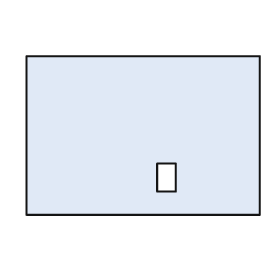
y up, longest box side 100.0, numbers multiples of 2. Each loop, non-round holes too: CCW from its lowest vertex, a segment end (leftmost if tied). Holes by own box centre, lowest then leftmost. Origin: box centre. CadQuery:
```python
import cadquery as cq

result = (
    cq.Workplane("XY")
    .moveTo(-50.0, -34.0)
    .lineTo(50.0, -34.0)
    .lineTo(50.0, 34.0)
    .lineTo(-50.0, 34.0)
    .close()
    .moveTo(6.0, -24.0)
    .lineTo(14.0, -24.0)
    .lineTo(14.0, -12.0)
    .lineTo(6.0, -12.0)
    .close()
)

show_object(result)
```